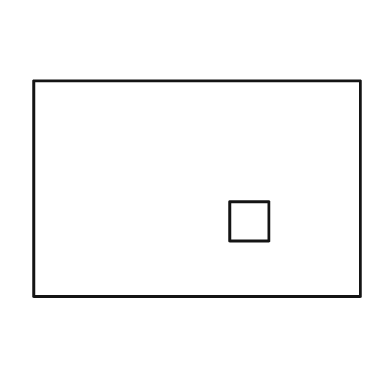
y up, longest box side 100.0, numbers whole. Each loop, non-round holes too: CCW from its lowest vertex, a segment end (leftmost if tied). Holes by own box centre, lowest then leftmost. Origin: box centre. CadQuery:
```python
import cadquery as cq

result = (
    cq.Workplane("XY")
    .moveTo(-50.0, -33.0)
    .lineTo(50.0, -33.0)
    .lineTo(50.0, 33.0)
    .lineTo(-50.0, 33.0)
    .close()
    .moveTo(10.0, -16.0)
    .lineTo(22.0, -16.0)
    .lineTo(22.0, -4.0)
    .lineTo(10.0, -4.0)
    .close()
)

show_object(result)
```